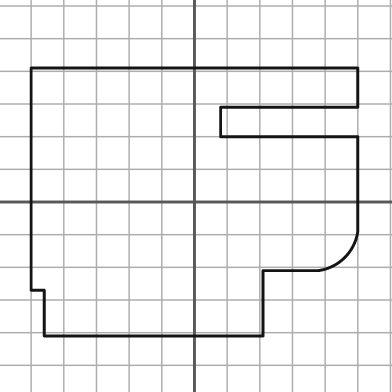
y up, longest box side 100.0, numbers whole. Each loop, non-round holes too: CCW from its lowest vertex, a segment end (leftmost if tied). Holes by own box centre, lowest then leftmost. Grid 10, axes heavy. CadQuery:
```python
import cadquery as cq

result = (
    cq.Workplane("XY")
    .moveTo(-46.0, -41.0)
    .lineTo(21.0, -41.0)
    .lineTo(21.0, -21.0)
    .lineTo(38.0, -21.0)
    .threePointArc((46.0, -17.0), (50.0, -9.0))
    .lineTo(50.0, 20.0)
    .lineTo(8.0, 20.0)
    .lineTo(8.0, 29.0)
    .lineTo(50.0, 29.0)
    .lineTo(50.0, 41.0)
    .lineTo(-50.0, 41.0)
    .lineTo(-50.0, -27.0)
    .lineTo(-46.0, -27.0)
    .close()
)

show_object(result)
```